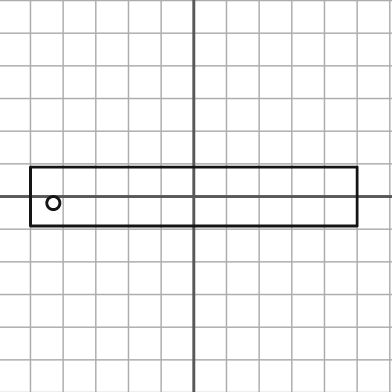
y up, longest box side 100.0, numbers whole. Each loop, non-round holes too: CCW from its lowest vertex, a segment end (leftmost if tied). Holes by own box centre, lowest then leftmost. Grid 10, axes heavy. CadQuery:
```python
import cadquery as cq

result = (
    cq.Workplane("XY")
    .moveTo(-50.0, -9.0)
    .lineTo(50.0, -9.0)
    .lineTo(50.0, 9.0)
    .lineTo(-50.0, 9.0)
    .close()
    .moveTo(-43.0, -2.0)
    .circle(2.0)
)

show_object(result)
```